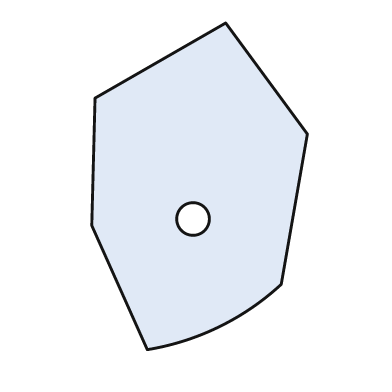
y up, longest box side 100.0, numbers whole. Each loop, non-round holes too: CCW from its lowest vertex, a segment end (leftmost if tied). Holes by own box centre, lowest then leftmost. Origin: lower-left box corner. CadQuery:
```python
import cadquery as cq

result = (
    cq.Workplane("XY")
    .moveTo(17.0, 0.0)
    .threePointArc((39.0, 7.0), (58.0, 20.0))
    .lineTo(66.0, 66.0)
    .lineTo(41.0, 100.0)
    .lineTo(1.0, 77.0)
    .lineTo(0.0, 38.0)
    .close()
    .moveTo(31.0, 40.0)
    .circle(5.0)
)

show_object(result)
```